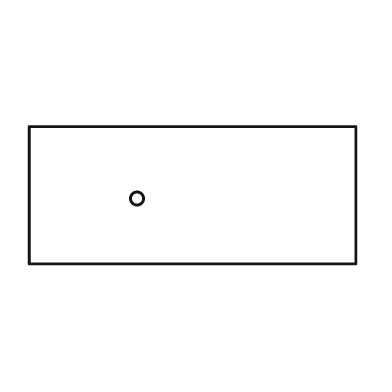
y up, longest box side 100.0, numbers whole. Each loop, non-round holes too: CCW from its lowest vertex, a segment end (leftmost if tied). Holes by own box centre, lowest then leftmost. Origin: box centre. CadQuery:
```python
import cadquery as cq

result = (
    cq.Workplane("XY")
    .moveTo(-50.0, -21.0)
    .lineTo(50.0, -21.0)
    .lineTo(50.0, 21.0)
    .lineTo(-50.0, 21.0)
    .close()
    .moveTo(-17.0, -1.0)
    .circle(2.0)
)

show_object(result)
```